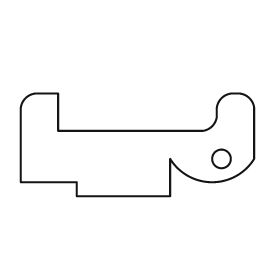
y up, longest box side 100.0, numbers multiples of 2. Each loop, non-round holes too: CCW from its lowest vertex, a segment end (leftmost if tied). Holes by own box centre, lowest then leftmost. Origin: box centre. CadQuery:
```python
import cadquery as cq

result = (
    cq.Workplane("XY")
    .moveTo(-26.0, -22.0)
    .lineTo(14.0, -22.0)
    .lineTo(14.0, -6.0)
    .threePointArc((32.0, -16.0), (50.0, -6.0))
    .lineTo(50.0, 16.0)
    .threePointArc((48.0, 20.0), (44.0, 22.0))
    .lineTo(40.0, 22.0)
    .threePointArc((36.0, 20.0), (34.0, 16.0))
    .lineTo(34.0, 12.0)
    .threePointArc((32.0, 8.0), (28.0, 6.0))
    .lineTo(-34.0, 6.0)
    .lineTo(-34.0, 22.0)
    .lineTo(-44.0, 22.0)
    .threePointArc((-48.0, 20.0), (-50.0, 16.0))
    .lineTo(-50.0, -16.0)
    .lineTo(-26.0, -16.0)
    .close()
    .moveTo(36.0, -6.0)
    .circle(4.0)
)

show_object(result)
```